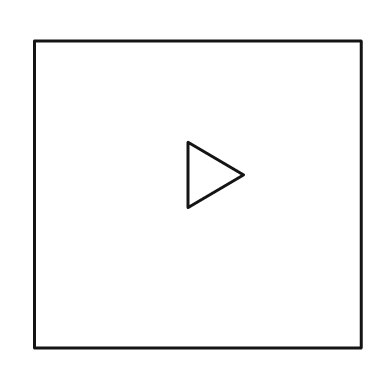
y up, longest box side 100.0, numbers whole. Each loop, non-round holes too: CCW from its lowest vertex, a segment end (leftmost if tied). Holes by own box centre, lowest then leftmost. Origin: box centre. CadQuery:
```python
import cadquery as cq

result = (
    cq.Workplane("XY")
    .moveTo(-50.0, -47.0)
    .lineTo(50.0, -47.0)
    .lineTo(50.0, 47.0)
    .lineTo(-50.0, 47.0)
    .close()
    .moveTo(-3.0, -4.0)
    .lineTo(14.0, 6.0)
    .lineTo(-3.0, 16.0)
    .close()
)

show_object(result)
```